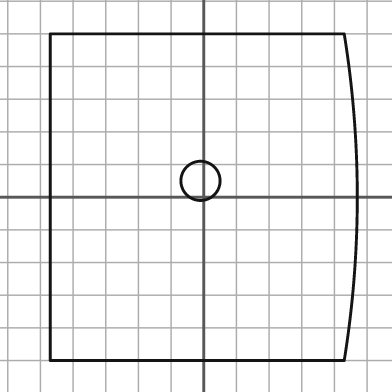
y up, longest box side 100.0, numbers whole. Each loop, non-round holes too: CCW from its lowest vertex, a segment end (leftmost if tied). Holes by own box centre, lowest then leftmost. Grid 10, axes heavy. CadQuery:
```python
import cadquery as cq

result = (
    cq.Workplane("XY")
    .moveTo(-47.0, -50.0)
    .lineTo(43.0, -50.0)
    .threePointArc((47.0, 0.0), (43.0, 50.0))
    .lineTo(-47.0, 50.0)
    .close()
    .moveTo(-1.0, 5.0)
    .circle(6.0)
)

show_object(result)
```